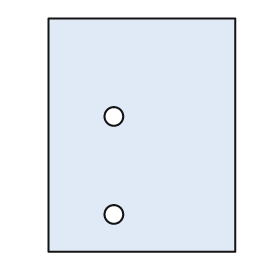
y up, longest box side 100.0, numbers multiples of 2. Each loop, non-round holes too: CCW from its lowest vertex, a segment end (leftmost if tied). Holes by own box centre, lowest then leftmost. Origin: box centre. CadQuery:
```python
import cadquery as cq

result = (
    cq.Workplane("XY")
    .moveTo(-40.0, -50.0)
    .lineTo(40.0, -50.0)
    .lineTo(40.0, 50.0)
    .lineTo(-40.0, 50.0)
    .close()
    .moveTo(-12.0, -34.0)
    .circle(4.0)
    .moveTo(-12.0, 8.0)
    .circle(4.0)
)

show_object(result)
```